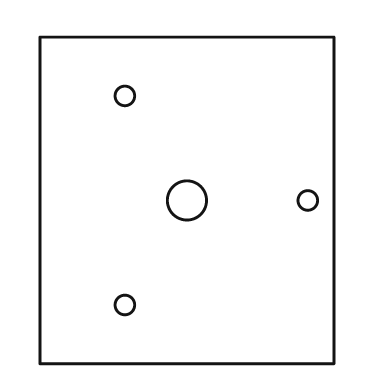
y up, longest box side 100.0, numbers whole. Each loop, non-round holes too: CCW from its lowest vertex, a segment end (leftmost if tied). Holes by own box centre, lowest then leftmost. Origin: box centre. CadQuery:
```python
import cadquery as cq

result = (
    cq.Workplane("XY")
    .moveTo(-45.0, -50.0)
    .lineTo(45.0, -50.0)
    .lineTo(45.0, 50.0)
    .lineTo(-45.0, 50.0)
    .close()
    .moveTo(-19.0, -32.0)
    .circle(3.0)
    .moveTo(0.0, 0.0)
    .circle(6.0)
    .moveTo(37.0, 0.0)
    .circle(3.0)
    .moveTo(-19.0, 32.0)
    .circle(3.0)
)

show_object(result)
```